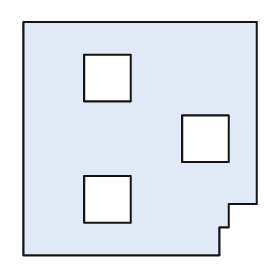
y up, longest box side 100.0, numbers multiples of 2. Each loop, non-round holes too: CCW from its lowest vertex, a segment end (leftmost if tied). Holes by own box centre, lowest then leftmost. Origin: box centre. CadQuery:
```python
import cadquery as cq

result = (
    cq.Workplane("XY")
    .moveTo(-50.0, -50.0)
    .lineTo(34.0, -50.0)
    .lineTo(34.0, -38.0)
    .lineTo(38.0, -38.0)
    .lineTo(38.0, -28.0)
    .lineTo(50.0, -28.0)
    .lineTo(50.0, 50.0)
    .lineTo(-50.0, 50.0)
    .close()
    .moveTo(-24.0, -36.0)
    .lineTo(-4.0, -36.0)
    .lineTo(-4.0, -16.0)
    .lineTo(-24.0, -16.0)
    .close()
    .moveTo(18.0, -10.0)
    .lineTo(38.0, -10.0)
    .lineTo(38.0, 10.0)
    .lineTo(18.0, 10.0)
    .close()
    .moveTo(-24.0, 16.0)
    .lineTo(-4.0, 16.0)
    .lineTo(-4.0, 36.0)
    .lineTo(-24.0, 36.0)
    .close()
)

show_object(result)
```